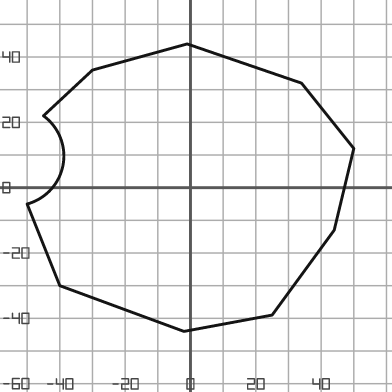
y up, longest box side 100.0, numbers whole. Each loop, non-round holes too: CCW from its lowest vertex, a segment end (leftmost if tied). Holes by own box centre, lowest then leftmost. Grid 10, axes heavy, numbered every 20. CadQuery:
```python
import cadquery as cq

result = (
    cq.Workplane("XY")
    .moveTo(-2.0, -44.0)
    .lineTo(25.0, -39.0)
    .lineTo(44.0, -13.0)
    .lineTo(50.0, 12.0)
    .lineTo(34.0, 32.0)
    .lineTo(-1.0, 44.0)
    .lineTo(-30.0, 36.0)
    .lineTo(-45.0, 22.0)
    .threePointArc((-39.0, 7.0), (-50.0, -5.0))
    .lineTo(-40.0, -30.0)
    .close()
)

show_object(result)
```